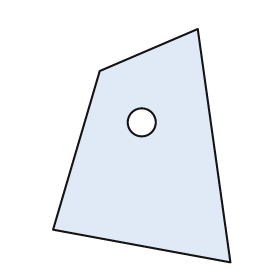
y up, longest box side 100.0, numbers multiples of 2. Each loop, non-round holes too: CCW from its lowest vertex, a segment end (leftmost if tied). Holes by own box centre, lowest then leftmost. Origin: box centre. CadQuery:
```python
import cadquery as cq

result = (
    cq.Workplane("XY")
    .moveTo(38.0, -50.0)
    .lineTo(24.0, 50.0)
    .lineTo(-18.0, 32.0)
    .lineTo(-38.0, -36.0)
    .close()
    .moveTo(0.0, 10.0)
    .circle(6.0)
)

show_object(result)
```